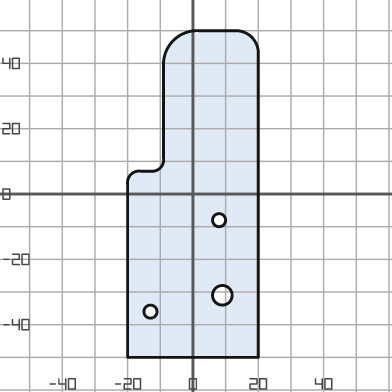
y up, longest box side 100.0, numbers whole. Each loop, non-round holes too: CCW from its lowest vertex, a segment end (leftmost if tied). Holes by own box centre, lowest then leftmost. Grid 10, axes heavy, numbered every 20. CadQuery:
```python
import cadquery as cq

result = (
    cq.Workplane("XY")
    .moveTo(-20.0, -50.0)
    .lineTo(20.0, -50.0)
    .lineTo(20.0, 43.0)
    .threePointArc((18.0, 48.0), (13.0, 50.0))
    .lineTo(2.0, 50.0)
    .threePointArc((-6.0, 47.0), (-9.0, 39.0))
    .lineTo(-9.0, 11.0)
    .threePointArc((-10.0, 8.0), (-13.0, 7.0))
    .lineTo(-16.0, 7.0)
    .threePointArc((-19.0, 6.0), (-20.0, 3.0))
    .close()
    .moveTo(-13.0, -36.0)
    .circle(2.0)
    .moveTo(9.0, -31.0)
    .circle(3.0)
    .moveTo(8.0, -8.0)
    .circle(2.0)
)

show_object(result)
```